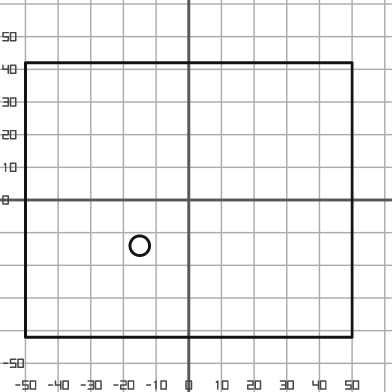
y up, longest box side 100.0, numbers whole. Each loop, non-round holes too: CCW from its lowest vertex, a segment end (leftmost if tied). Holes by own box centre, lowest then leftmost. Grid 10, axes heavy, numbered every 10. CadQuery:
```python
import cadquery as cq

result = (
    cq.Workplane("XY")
    .moveTo(-50.0, -42.0)
    .lineTo(50.0, -42.0)
    .lineTo(50.0, 42.0)
    .lineTo(-50.0, 42.0)
    .close()
    .moveTo(-15.0, -14.0)
    .circle(3.0)
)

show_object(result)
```